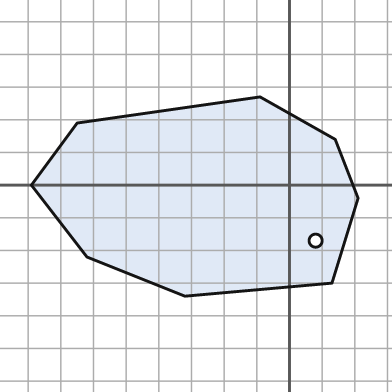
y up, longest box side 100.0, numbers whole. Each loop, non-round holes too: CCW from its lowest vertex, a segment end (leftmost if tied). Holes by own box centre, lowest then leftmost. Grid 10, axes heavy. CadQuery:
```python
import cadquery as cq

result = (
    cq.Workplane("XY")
    .moveTo(-32.0, -34.0)
    .lineTo(13.0, -30.0)
    .lineTo(21.0, -4.0)
    .lineTo(14.0, 14.0)
    .lineTo(-9.0, 27.0)
    .lineTo(-65.0, 19.0)
    .lineTo(-79.0, 0.0)
    .lineTo(-62.0, -22.0)
    .close()
    .moveTo(8.0, -17.0)
    .circle(2.0)
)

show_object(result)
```